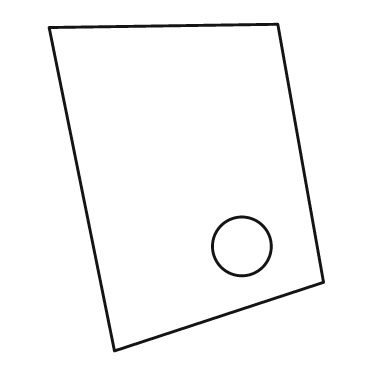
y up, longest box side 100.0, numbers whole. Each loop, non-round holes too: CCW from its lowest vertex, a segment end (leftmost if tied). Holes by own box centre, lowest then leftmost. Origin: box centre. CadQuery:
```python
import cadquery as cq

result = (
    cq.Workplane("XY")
    .moveTo(-22.0, -50.0)
    .lineTo(42.0, -29.0)
    .lineTo(28.0, 50.0)
    .lineTo(-42.0, 49.0)
    .close()
    .moveTo(17.0, -18.0)
    .circle(9.0)
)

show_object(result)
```